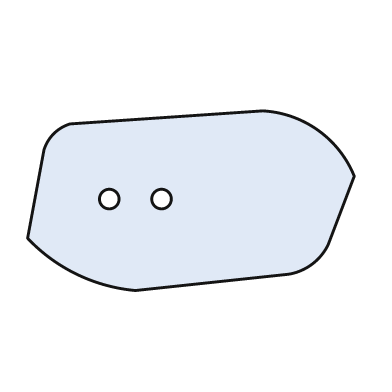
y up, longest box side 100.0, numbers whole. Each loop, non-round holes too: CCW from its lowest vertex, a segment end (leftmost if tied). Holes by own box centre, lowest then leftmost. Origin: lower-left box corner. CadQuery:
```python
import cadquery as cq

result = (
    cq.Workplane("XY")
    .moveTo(33.0, 0.0)
    .lineTo(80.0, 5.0)
    .threePointArc((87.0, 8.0), (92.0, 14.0))
    .lineTo(100.0, 35.0)
    .threePointArc((89.0, 49.0), (72.0, 55.0))
    .lineTo(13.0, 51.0)
    .threePointArc((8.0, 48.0), (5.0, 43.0))
    .lineTo(0.0, 16.0)
    .threePointArc((15.0, 5.0), (33.0, 0.0))
    .close()
    .moveTo(25.0, 28.0)
    .circle(3.0)
    .moveTo(41.0, 28.0)
    .circle(3.0)
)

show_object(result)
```